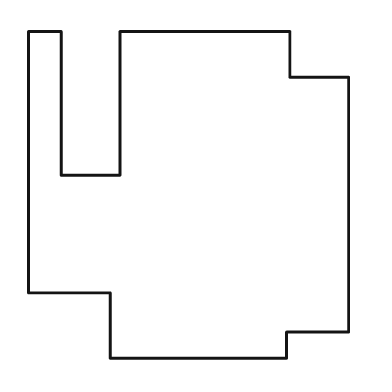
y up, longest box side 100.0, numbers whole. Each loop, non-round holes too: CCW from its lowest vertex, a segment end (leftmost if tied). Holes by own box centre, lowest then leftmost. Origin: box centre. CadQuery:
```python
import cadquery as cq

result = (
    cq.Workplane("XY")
    .moveTo(-24.0, -50.0)
    .lineTo(30.0, -50.0)
    .lineTo(30.0, -42.0)
    .lineTo(49.0, -42.0)
    .lineTo(49.0, 36.0)
    .lineTo(31.0, 36.0)
    .lineTo(31.0, 50.0)
    .lineTo(-21.0, 50.0)
    .lineTo(-21.0, 6.0)
    .lineTo(-39.0, 6.0)
    .lineTo(-39.0, 50.0)
    .lineTo(-49.0, 50.0)
    .lineTo(-49.0, -30.0)
    .lineTo(-24.0, -30.0)
    .close()
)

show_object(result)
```